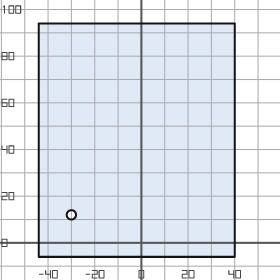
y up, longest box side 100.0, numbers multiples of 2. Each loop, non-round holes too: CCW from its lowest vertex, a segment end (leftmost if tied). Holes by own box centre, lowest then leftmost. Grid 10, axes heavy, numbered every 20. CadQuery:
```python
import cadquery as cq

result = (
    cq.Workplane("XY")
    .moveTo(-44.0, -6.0)
    .lineTo(40.0, -6.0)
    .lineTo(40.0, 94.0)
    .lineTo(-44.0, 94.0)
    .close()
    .moveTo(-30.0, 12.0)
    .circle(2.0)
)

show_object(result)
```